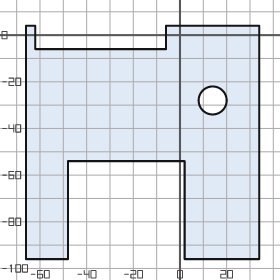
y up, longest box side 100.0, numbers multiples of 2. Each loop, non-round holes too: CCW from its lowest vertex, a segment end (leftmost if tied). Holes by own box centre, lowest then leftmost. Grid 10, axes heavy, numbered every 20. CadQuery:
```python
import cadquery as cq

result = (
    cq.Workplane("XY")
    .moveTo(-66.0, -96.0)
    .lineTo(-48.0, -96.0)
    .lineTo(-48.0, -54.0)
    .lineTo(2.0, -54.0)
    .lineTo(2.0, -96.0)
    .lineTo(34.0, -96.0)
    .lineTo(34.0, 4.0)
    .lineTo(-6.0, 4.0)
    .lineTo(-6.0, -6.0)
    .lineTo(-62.0, -6.0)
    .lineTo(-62.0, 4.0)
    .lineTo(-66.0, 4.0)
    .close()
    .moveTo(14.0, -28.0)
    .circle(6.0)
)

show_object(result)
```